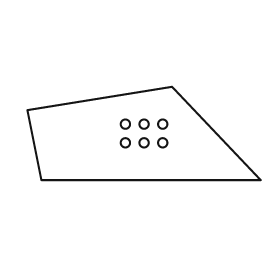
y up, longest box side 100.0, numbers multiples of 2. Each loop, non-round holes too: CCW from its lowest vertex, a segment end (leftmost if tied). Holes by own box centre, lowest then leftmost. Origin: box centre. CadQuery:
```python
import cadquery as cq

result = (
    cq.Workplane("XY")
    .moveTo(-44.0, -20.0)
    .lineTo(50.0, -20.0)
    .lineTo(12.0, 20.0)
    .lineTo(-50.0, 10.0)
    .close()
    .moveTo(-8.0, -4.0)
    .circle(2.0)
    .moveTo(0.0, -4.0)
    .circle(2.0)
    .moveTo(8.0, -4.0)
    .circle(2.0)
    .moveTo(-8.0, 4.0)
    .circle(2.0)
    .moveTo(0.0, 4.0)
    .circle(2.0)
    .moveTo(8.0, 4.0)
    .circle(2.0)
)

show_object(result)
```